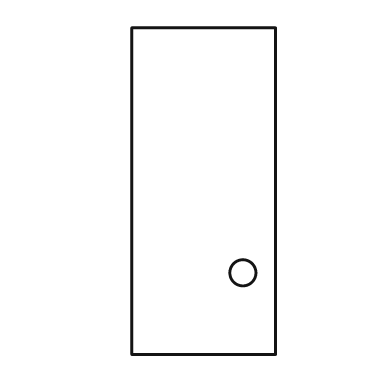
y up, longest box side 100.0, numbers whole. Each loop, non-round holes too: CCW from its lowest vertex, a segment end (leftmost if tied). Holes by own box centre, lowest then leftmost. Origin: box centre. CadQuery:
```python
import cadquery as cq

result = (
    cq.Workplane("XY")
    .moveTo(-22.0, -50.0)
    .lineTo(22.0, -50.0)
    .lineTo(22.0, 50.0)
    .lineTo(-22.0, 50.0)
    .close()
    .moveTo(12.0, -25.0)
    .circle(4.0)
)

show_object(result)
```